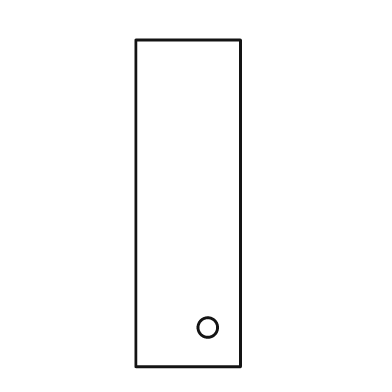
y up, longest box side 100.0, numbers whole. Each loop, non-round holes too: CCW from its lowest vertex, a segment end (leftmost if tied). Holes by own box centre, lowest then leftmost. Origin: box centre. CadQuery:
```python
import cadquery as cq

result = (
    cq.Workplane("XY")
    .moveTo(-16.0, -50.0)
    .lineTo(16.0, -50.0)
    .lineTo(16.0, 50.0)
    .lineTo(-16.0, 50.0)
    .close()
    .moveTo(6.0, -38.0)
    .circle(3.0)
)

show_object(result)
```